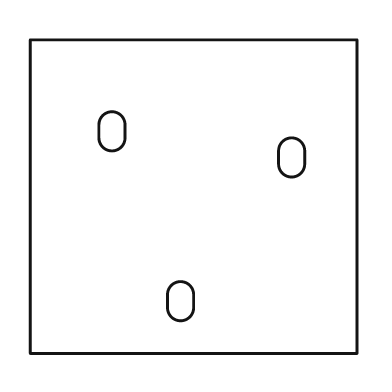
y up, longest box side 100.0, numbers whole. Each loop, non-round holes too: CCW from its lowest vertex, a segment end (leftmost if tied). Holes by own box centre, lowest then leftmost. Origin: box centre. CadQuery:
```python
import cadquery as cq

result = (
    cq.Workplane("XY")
    .moveTo(-50.0, -48.0)
    .lineTo(50.0, -48.0)
    .lineTo(50.0, 48.0)
    .lineTo(-50.0, 48.0)
    .close()
    .moveTo(-8.0, -34.0)
    .threePointArc((-4.0, -38.0), (0.0, -34.0))
    .lineTo(0.0, -30.0)
    .threePointArc((-4.0, -26.0), (-8.0, -30.0))
    .close()
    .moveTo(26.0, 10.0)
    .threePointArc((30.0, 6.0), (34.0, 10.0))
    .lineTo(34.0, 14.0)
    .threePointArc((30.0, 18.0), (26.0, 14.0))
    .close()
    .moveTo(-29.0, 18.0)
    .threePointArc((-25.0, 14.0), (-21.0, 18.0))
    .lineTo(-21.0, 22.0)
    .threePointArc((-25.0, 26.0), (-29.0, 22.0))
    .close()
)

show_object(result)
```